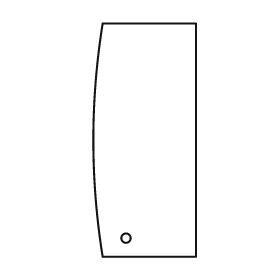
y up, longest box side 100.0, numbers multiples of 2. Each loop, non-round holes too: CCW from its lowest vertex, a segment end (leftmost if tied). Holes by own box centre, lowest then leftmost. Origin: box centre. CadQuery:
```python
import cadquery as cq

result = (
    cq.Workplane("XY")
    .moveTo(-18.0, -50.0)
    .lineTo(22.0, -50.0)
    .lineTo(22.0, 50.0)
    .lineTo(-18.0, 50.0)
    .threePointArc((-22.0, 0.0), (-18.0, -50.0))
    .close()
    .moveTo(-8.0, -42.0)
    .circle(2.0)
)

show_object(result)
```